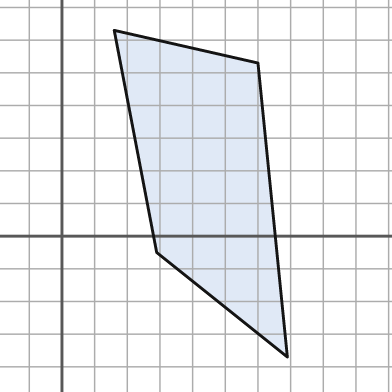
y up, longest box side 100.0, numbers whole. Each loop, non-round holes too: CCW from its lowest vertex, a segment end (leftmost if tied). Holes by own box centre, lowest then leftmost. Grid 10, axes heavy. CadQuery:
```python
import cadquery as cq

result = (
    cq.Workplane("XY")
    .moveTo(69.0, -37.0)
    .lineTo(60.0, 53.0)
    .lineTo(16.0, 63.0)
    .lineTo(29.0, -5.0)
    .close()
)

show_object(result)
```